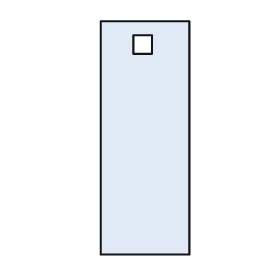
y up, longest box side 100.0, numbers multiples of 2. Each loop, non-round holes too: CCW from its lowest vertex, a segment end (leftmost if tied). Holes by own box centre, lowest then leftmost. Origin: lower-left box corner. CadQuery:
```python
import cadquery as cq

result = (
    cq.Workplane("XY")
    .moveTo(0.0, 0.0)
    .lineTo(38.0, 0.0)
    .lineTo(38.0, 100.0)
    .lineTo(0.0, 100.0)
    .close()
    .moveTo(14.0, 86.0)
    .lineTo(22.0, 86.0)
    .lineTo(22.0, 94.0)
    .lineTo(14.0, 94.0)
    .close()
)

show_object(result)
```